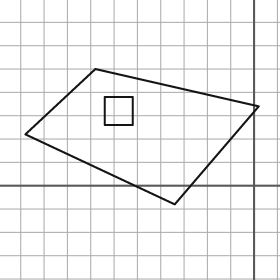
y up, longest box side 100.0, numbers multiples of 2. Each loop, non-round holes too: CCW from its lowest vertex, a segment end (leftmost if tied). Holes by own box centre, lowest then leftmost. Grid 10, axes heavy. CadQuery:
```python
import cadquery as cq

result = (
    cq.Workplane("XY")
    .moveTo(-34.0, -8.0)
    .lineTo(2.0, 34.0)
    .lineTo(-68.0, 50.0)
    .lineTo(-98.0, 22.0)
    .close()
    .moveTo(-64.0, 26.0)
    .lineTo(-52.0, 26.0)
    .lineTo(-52.0, 38.0)
    .lineTo(-64.0, 38.0)
    .close()
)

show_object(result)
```